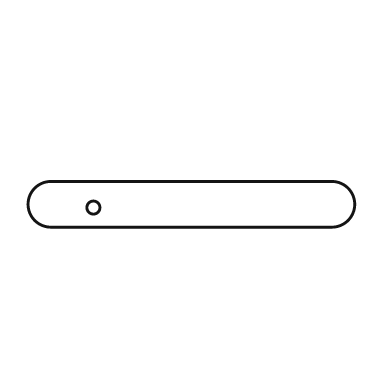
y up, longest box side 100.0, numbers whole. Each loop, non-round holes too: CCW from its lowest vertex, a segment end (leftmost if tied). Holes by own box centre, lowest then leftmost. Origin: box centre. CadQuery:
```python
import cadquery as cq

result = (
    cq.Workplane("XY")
    .moveTo(-43.0, -7.0)
    .lineTo(43.0, -7.0)
    .threePointArc((50.0, 0.0), (43.0, 7.0))
    .lineTo(-43.0, 7.0)
    .threePointArc((-50.0, 0.0), (-43.0, -7.0))
    .close()
    .moveTo(-30.0, -1.0)
    .circle(2.0)
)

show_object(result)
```